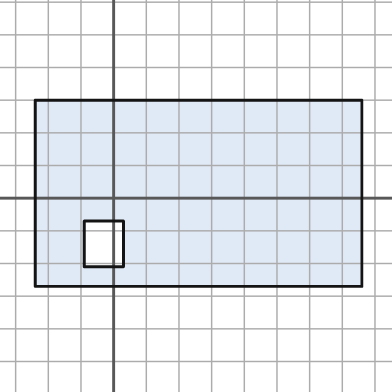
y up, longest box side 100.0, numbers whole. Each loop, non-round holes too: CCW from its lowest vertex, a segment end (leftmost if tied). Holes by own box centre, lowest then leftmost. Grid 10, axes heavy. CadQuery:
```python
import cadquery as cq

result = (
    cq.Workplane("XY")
    .moveTo(-24.0, -27.0)
    .lineTo(76.0, -27.0)
    .lineTo(76.0, 30.0)
    .lineTo(-24.0, 30.0)
    .close()
    .moveTo(-9.0, -21.0)
    .lineTo(3.0, -21.0)
    .lineTo(3.0, -7.0)
    .lineTo(-9.0, -7.0)
    .close()
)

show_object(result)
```